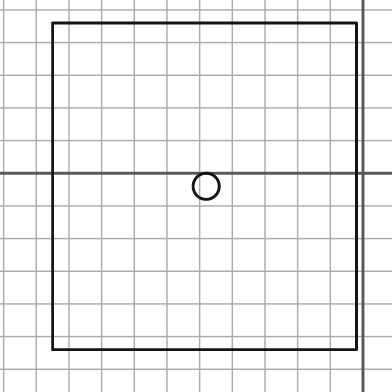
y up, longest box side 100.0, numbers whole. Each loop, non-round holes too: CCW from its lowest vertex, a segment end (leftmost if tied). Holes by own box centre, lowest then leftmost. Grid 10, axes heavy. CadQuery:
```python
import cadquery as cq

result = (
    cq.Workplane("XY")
    .moveTo(-95.0, -54.0)
    .lineTo(-2.0, -54.0)
    .lineTo(-2.0, 46.0)
    .lineTo(-95.0, 46.0)
    .close()
    .moveTo(-48.0, -4.0)
    .circle(4.0)
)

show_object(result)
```